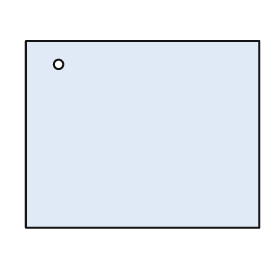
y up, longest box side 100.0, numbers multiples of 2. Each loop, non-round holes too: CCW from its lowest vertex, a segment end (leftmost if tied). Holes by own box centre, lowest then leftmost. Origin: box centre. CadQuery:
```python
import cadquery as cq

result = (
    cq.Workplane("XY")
    .moveTo(-50.0, -40.0)
    .lineTo(50.0, -40.0)
    .lineTo(50.0, 40.0)
    .lineTo(-50.0, 40.0)
    .close()
    .moveTo(-36.0, 30.0)
    .circle(2.0)
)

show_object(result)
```